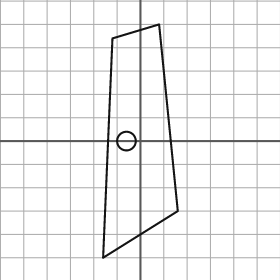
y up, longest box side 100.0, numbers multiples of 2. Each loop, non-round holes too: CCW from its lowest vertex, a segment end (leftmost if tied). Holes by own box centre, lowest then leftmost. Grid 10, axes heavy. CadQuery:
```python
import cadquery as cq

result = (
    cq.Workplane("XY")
    .moveTo(-16.0, -50.0)
    .lineTo(16.0, -30.0)
    .lineTo(8.0, 50.0)
    .lineTo(-12.0, 44.0)
    .close()
    .moveTo(-6.0, 0.0)
    .circle(4.0)
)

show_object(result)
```